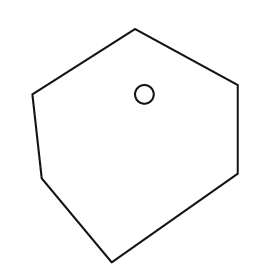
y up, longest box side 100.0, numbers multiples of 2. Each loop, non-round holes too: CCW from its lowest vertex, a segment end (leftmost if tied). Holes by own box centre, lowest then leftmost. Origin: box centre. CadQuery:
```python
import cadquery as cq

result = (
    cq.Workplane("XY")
    .moveTo(-10.0, -50.0)
    .lineTo(44.0, -12.0)
    .lineTo(44.0, 26.0)
    .lineTo(0.0, 50.0)
    .lineTo(-44.0, 22.0)
    .lineTo(-40.0, -14.0)
    .close()
    .moveTo(4.0, 22.0)
    .circle(4.0)
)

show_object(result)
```